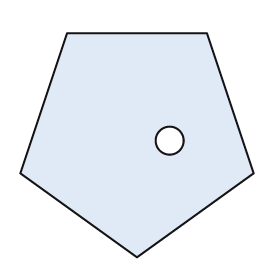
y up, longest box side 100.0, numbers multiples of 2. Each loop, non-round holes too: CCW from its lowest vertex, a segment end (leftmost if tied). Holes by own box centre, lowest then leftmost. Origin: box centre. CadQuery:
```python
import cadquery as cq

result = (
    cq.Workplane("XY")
    .moveTo(0.0, -48.0)
    .lineTo(50.0, -12.0)
    .lineTo(30.0, 48.0)
    .lineTo(-30.0, 48.0)
    .lineTo(-50.0, -12.0)
    .close()
    .moveTo(14.0, 2.0)
    .circle(6.0)
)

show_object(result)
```